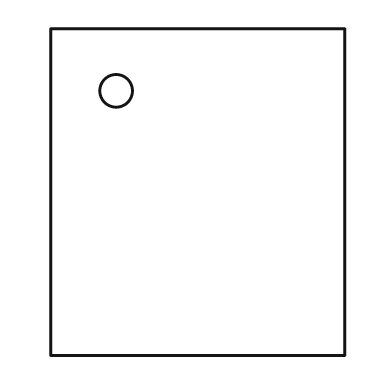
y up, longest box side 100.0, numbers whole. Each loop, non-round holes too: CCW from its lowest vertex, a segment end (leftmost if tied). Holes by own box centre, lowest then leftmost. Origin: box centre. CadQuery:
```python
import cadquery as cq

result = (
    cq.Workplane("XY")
    .moveTo(-45.0, -50.0)
    .lineTo(45.0, -50.0)
    .lineTo(45.0, 50.0)
    .lineTo(-45.0, 50.0)
    .close()
    .moveTo(-25.0, 31.0)
    .circle(5.0)
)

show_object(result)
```